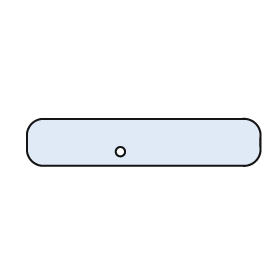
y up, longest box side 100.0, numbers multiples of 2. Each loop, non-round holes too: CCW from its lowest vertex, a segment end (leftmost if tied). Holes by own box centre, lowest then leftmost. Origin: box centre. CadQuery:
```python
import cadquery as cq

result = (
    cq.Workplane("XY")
    .moveTo(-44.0, -10.0)
    .lineTo(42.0, -10.0)
    .threePointArc((48.0, -8.0), (50.0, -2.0))
    .lineTo(50.0, 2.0)
    .threePointArc((48.0, 8.0), (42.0, 10.0))
    .lineTo(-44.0, 10.0)
    .threePointArc((-48.0, 8.0), (-50.0, 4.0))
    .lineTo(-50.0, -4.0)
    .threePointArc((-48.0, -8.0), (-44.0, -10.0))
    .close()
    .moveTo(-10.0, -4.0)
    .circle(2.0)
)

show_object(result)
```